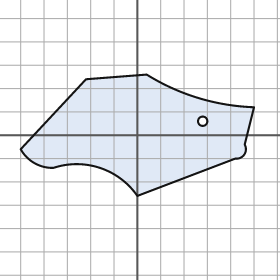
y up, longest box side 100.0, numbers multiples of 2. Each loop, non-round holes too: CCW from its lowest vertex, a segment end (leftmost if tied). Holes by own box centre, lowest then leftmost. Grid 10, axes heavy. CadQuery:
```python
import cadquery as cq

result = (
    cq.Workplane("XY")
    .moveTo(0.0, -26.0)
    .lineTo(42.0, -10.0)
    .threePointArc((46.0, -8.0), (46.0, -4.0))
    .lineTo(50.0, 12.0)
    .threePointArc((26.0, 16.0), (4.0, 26.0))
    .lineTo(-22.0, 24.0)
    .lineTo(-50.0, -6.0)
    .threePointArc((-44.0, -12.0), (-36.0, -14.0))
    .threePointArc((-16.0, -14.0), (0.0, -26.0))
    .close()
    .moveTo(28.0, 6.0)
    .circle(2.0)
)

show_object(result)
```